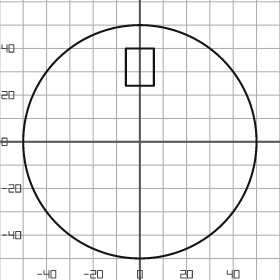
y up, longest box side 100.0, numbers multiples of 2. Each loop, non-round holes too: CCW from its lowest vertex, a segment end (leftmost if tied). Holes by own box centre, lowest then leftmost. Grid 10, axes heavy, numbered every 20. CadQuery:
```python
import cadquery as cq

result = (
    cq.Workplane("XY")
    .moveTo(0.0, 0.0)
    .circle(50.0)
    .moveTo(-6.0, 24.0)
    .lineTo(6.0, 24.0)
    .lineTo(6.0, 40.0)
    .lineTo(-6.0, 40.0)
    .close()
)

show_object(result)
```